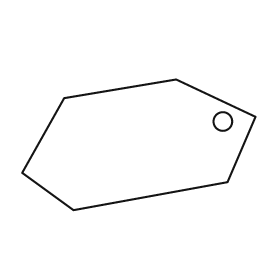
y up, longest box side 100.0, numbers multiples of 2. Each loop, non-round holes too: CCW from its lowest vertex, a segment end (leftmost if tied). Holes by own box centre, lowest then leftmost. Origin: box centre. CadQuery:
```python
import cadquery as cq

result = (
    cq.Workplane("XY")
    .moveTo(-28.0, -28.0)
    .lineTo(38.0, -16.0)
    .lineTo(50.0, 12.0)
    .lineTo(16.0, 28.0)
    .lineTo(-32.0, 20.0)
    .lineTo(-50.0, -12.0)
    .close()
    .moveTo(36.0, 10.0)
    .circle(4.0)
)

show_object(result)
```